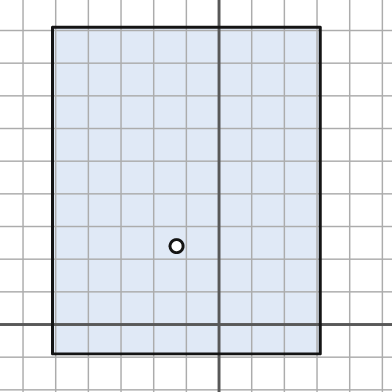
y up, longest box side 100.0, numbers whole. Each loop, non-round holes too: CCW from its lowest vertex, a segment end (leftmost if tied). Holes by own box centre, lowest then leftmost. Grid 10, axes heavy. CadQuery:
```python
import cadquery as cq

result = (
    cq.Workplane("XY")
    .moveTo(-51.0, -9.0)
    .lineTo(31.0, -9.0)
    .lineTo(31.0, 91.0)
    .lineTo(-51.0, 91.0)
    .close()
    .moveTo(-13.0, 24.0)
    .circle(2.0)
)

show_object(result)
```